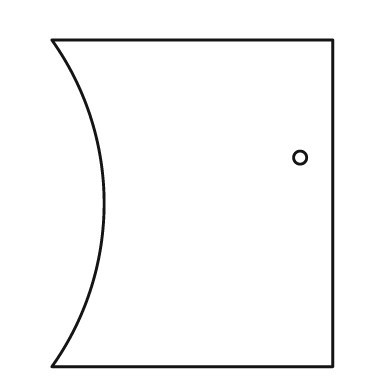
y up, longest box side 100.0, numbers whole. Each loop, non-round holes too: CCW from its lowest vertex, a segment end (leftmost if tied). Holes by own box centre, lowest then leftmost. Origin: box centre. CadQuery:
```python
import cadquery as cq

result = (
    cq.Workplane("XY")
    .moveTo(-43.0, -50.0)
    .lineTo(43.0, -50.0)
    .lineTo(43.0, 50.0)
    .lineTo(-43.0, 50.0)
    .threePointArc((-27.0, 0.0), (-43.0, -50.0))
    .close()
    .moveTo(33.0, 14.0)
    .circle(2.0)
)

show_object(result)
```